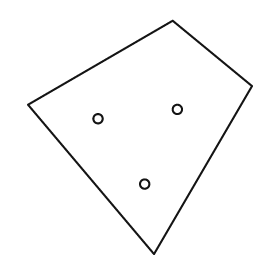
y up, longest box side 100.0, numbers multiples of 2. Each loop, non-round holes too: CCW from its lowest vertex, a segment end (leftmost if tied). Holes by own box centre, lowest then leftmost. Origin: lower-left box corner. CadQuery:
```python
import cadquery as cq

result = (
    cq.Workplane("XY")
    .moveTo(54.0, 0.0)
    .lineTo(96.0, 72.0)
    .lineTo(62.0, 100.0)
    .lineTo(0.0, 64.0)
    .close()
    .moveTo(50.0, 30.0)
    .circle(2.0)
    .moveTo(30.0, 58.0)
    .circle(2.0)
    .moveTo(64.0, 62.0)
    .circle(2.0)
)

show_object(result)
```